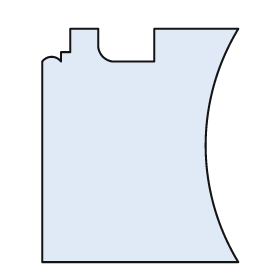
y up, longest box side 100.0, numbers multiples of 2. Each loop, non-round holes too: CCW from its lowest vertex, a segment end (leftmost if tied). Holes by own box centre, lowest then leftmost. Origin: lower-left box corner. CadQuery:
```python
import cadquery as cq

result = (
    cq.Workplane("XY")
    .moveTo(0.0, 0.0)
    .lineTo(84.0, 0.0)
    .threePointArc((70.0, 50.0), (84.0, 100.0))
    .lineTo(48.0, 100.0)
    .lineTo(48.0, 86.0)
    .lineTo(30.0, 86.0)
    .threePointArc((26.0, 88.0), (24.0, 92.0))
    .lineTo(24.0, 100.0)
    .lineTo(12.0, 100.0)
    .lineTo(12.0, 90.0)
    .lineTo(8.0, 90.0)
    .lineTo(8.0, 86.0)
    .threePointArc((4.0, 88.0), (0.0, 86.0))
    .close()
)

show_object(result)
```